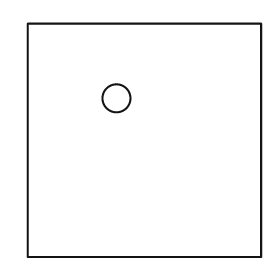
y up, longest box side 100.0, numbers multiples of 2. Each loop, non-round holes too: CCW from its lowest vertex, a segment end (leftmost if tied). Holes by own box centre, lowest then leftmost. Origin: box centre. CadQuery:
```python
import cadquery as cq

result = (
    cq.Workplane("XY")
    .moveTo(-50.0, -50.0)
    .lineTo(50.0, -50.0)
    .lineTo(50.0, 50.0)
    .lineTo(-50.0, 50.0)
    .close()
    .moveTo(-12.0, 18.0)
    .circle(6.0)
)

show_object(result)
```